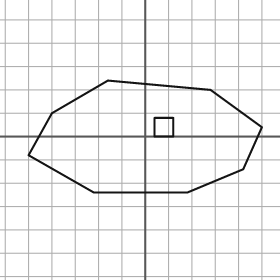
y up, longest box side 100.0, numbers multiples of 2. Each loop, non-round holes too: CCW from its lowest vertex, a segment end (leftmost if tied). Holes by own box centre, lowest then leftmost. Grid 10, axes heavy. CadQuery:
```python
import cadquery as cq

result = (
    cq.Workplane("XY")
    .moveTo(-22.0, -24.0)
    .lineTo(18.0, -24.0)
    .lineTo(42.0, -14.0)
    .lineTo(50.0, 4.0)
    .lineTo(28.0, 20.0)
    .lineTo(-16.0, 24.0)
    .lineTo(-40.0, 10.0)
    .lineTo(-50.0, -8.0)
    .close()
    .moveTo(4.0, 0.0)
    .lineTo(12.0, 0.0)
    .lineTo(12.0, 8.0)
    .lineTo(4.0, 8.0)
    .close()
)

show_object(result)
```